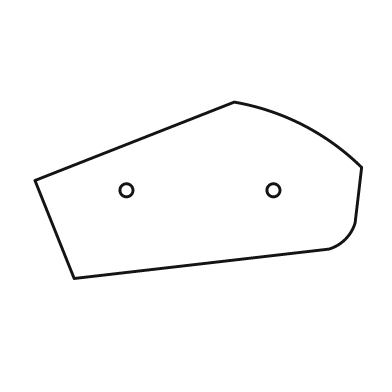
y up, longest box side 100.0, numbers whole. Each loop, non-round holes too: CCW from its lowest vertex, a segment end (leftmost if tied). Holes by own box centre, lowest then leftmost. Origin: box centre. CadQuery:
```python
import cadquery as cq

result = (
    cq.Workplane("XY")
    .moveTo(-38.0, -27.0)
    .lineTo(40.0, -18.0)
    .threePointArc((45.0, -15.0), (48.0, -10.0))
    .lineTo(50.0, 7.0)
    .threePointArc((32.0, 20.0), (11.0, 27.0))
    .lineTo(-50.0, 3.0)
    .close()
    .moveTo(-22.0, 0.0)
    .circle(2.0)
    .moveTo(23.0, 0.0)
    .circle(2.0)
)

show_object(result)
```